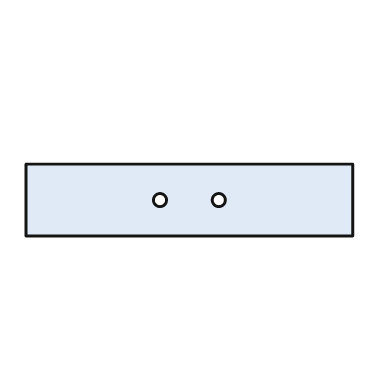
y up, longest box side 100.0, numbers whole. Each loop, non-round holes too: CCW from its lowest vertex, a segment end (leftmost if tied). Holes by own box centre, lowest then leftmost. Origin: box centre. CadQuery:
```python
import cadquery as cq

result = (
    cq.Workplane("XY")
    .moveTo(-50.0, -11.0)
    .lineTo(50.0, -11.0)
    .lineTo(50.0, 11.0)
    .lineTo(-50.0, 11.0)
    .close()
    .moveTo(-9.0, 0.0)
    .circle(2.0)
    .moveTo(9.0, 0.0)
    .circle(2.0)
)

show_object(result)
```